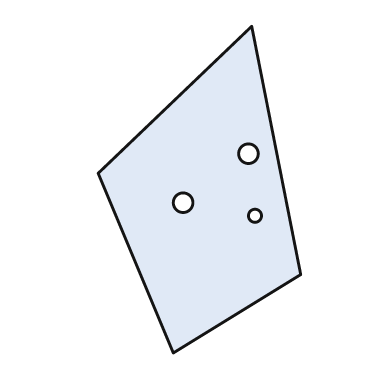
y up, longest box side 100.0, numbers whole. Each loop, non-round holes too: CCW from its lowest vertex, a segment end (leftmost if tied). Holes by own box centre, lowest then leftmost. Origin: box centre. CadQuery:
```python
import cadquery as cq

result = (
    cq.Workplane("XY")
    .moveTo(-8.0, -50.0)
    .lineTo(31.0, -26.0)
    .lineTo(16.0, 50.0)
    .lineTo(-31.0, 5.0)
    .close()
    .moveTo(17.0, -8.0)
    .circle(2.0)
    .moveTo(-5.0, -4.0)
    .circle(3.0)
    .moveTo(15.0, 11.0)
    .circle(3.0)
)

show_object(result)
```